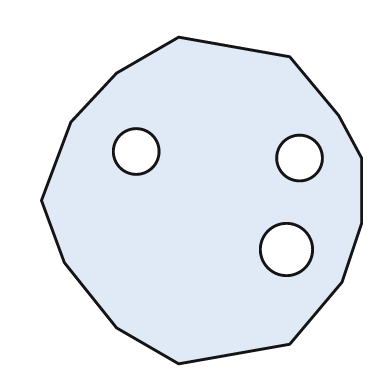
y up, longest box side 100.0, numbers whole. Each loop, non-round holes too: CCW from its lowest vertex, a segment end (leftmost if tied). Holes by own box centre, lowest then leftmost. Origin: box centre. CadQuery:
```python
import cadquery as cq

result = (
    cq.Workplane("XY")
    .moveTo(-7.0, -50.0)
    .lineTo(27.0, -44.0)
    .lineTo(43.0, -25.0)
    .lineTo(49.0, -7.0)
    .lineTo(49.0, 13.0)
    .lineTo(42.0, 26.0)
    .lineTo(27.0, 44.0)
    .lineTo(-7.0, 50.0)
    .lineTo(-26.0, 39.0)
    .lineTo(-40.0, 24.0)
    .lineTo(-49.0, 0.0)
    .lineTo(-42.0, -19.0)
    .lineTo(-26.0, -39.0)
    .close()
    .moveTo(26.0, -15.0)
    .circle(8.0)
    .moveTo(30.0, 13.0)
    .circle(7.0)
    .moveTo(-20.0, 15.0)
    .circle(7.0)
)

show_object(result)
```